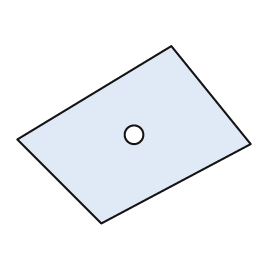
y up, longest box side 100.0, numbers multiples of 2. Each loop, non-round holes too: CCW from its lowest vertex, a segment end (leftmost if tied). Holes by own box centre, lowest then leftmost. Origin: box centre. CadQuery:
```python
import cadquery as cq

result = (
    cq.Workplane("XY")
    .moveTo(-14.0, -38.0)
    .lineTo(50.0, -4.0)
    .lineTo(16.0, 38.0)
    .lineTo(-50.0, -2.0)
    .close()
    .moveTo(0.0, 0.0)
    .circle(4.0)
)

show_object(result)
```